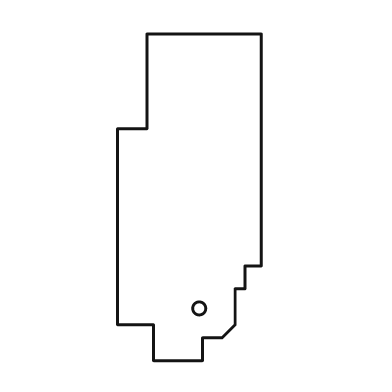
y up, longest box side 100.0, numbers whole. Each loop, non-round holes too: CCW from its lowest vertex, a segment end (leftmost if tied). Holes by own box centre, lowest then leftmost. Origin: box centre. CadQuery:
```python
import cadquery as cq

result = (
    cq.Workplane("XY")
    .moveTo(-11.0, -50.0)
    .lineTo(4.0, -50.0)
    .lineTo(4.0, -43.0)
    .lineTo(10.0, -43.0)
    .lineTo(14.0, -39.0)
    .lineTo(14.0, -28.0)
    .lineTo(17.0, -28.0)
    .lineTo(17.0, -21.0)
    .lineTo(22.0, -21.0)
    .lineTo(22.0, 50.0)
    .lineTo(-13.0, 50.0)
    .lineTo(-13.0, 21.0)
    .lineTo(-22.0, 21.0)
    .lineTo(-22.0, -39.0)
    .lineTo(-11.0, -39.0)
    .close()
    .moveTo(3.0, -34.0)
    .circle(2.0)
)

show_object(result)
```